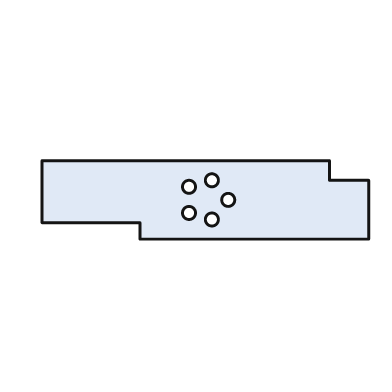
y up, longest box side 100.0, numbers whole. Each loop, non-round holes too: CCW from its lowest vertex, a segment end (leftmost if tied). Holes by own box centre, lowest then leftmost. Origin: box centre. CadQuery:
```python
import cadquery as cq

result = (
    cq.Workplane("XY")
    .moveTo(-20.0, -12.0)
    .lineTo(50.0, -12.0)
    .lineTo(50.0, 6.0)
    .lineTo(38.0, 6.0)
    .lineTo(38.0, 12.0)
    .lineTo(-50.0, 12.0)
    .lineTo(-50.0, -7.0)
    .lineTo(-20.0, -7.0)
    .close()
    .moveTo(2.0, -6.0)
    .circle(2.0)
    .moveTo(-5.0, -4.0)
    .circle(2.0)
    .moveTo(7.0, 0.0)
    .circle(2.0)
    .moveTo(-5.0, 4.0)
    .circle(2.0)
    .moveTo(2.0, 6.0)
    .circle(2.0)
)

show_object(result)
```